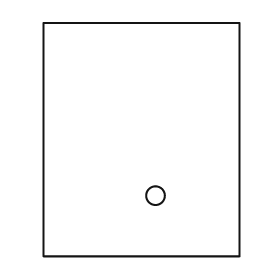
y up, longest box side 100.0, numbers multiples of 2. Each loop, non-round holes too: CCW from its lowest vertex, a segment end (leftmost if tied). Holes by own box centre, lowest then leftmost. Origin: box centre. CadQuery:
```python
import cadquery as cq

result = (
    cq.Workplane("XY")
    .moveTo(-42.0, -50.0)
    .lineTo(42.0, -50.0)
    .lineTo(42.0, 50.0)
    .lineTo(-42.0, 50.0)
    .close()
    .moveTo(6.0, -24.0)
    .circle(4.0)
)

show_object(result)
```